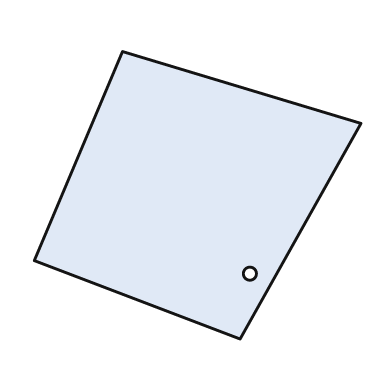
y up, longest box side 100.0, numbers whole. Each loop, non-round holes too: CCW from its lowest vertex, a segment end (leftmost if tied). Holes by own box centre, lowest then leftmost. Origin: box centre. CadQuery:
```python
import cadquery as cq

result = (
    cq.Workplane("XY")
    .moveTo(13.0, -44.0)
    .lineTo(50.0, 22.0)
    .lineTo(-23.0, 44.0)
    .lineTo(-50.0, -20.0)
    .close()
    .moveTo(16.0, -24.0)
    .circle(2.0)
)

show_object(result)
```